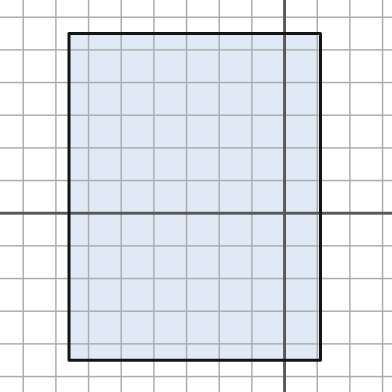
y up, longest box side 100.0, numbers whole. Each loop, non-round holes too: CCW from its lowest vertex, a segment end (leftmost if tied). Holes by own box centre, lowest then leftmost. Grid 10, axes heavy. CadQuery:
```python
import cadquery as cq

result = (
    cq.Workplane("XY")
    .moveTo(-66.0, -45.0)
    .lineTo(11.0, -45.0)
    .lineTo(11.0, 55.0)
    .lineTo(-66.0, 55.0)
    .close()
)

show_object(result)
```